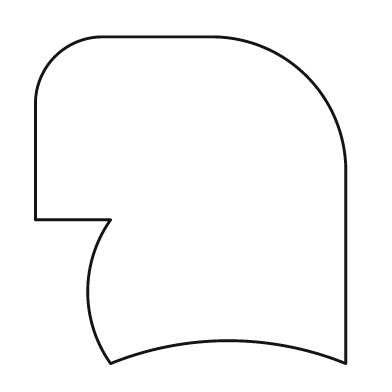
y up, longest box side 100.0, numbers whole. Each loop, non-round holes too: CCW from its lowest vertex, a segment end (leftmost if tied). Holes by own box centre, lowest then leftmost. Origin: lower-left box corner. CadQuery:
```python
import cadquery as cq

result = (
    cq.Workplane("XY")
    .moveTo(23.0, 0.0)
    .threePointArc((59.0, 7.0), (95.0, 0.0))
    .lineTo(95.0, 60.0)
    .threePointArc((83.0, 88.0), (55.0, 100.0))
    .lineTo(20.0, 100.0)
    .threePointArc((6.0, 94.0), (0.0, 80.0))
    .lineTo(0.0, 44.0)
    .lineTo(23.0, 44.0)
    .threePointArc((16.0, 22.0), (23.0, 0.0))
    .close()
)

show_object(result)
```